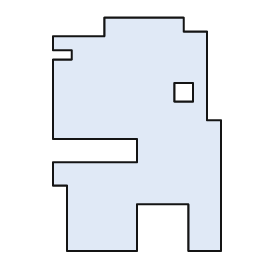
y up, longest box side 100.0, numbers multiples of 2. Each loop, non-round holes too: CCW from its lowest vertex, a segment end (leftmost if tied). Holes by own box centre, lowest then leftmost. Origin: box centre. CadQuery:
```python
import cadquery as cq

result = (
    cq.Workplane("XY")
    .moveTo(-30.0, -50.0)
    .lineTo(0.0, -50.0)
    .lineTo(0.0, -30.0)
    .lineTo(22.0, -30.0)
    .lineTo(22.0, -50.0)
    .lineTo(36.0, -50.0)
    .lineTo(36.0, 6.0)
    .lineTo(30.0, 6.0)
    .lineTo(30.0, 44.0)
    .lineTo(20.0, 44.0)
    .lineTo(20.0, 50.0)
    .lineTo(-14.0, 50.0)
    .lineTo(-14.0, 42.0)
    .lineTo(-36.0, 42.0)
    .lineTo(-36.0, 36.0)
    .lineTo(-28.0, 36.0)
    .lineTo(-28.0, 32.0)
    .lineTo(-36.0, 32.0)
    .lineTo(-36.0, -2.0)
    .lineTo(0.0, -2.0)
    .lineTo(0.0, -12.0)
    .lineTo(-36.0, -12.0)
    .lineTo(-36.0, -22.0)
    .lineTo(-30.0, -22.0)
    .close()
    .moveTo(16.0, 14.0)
    .lineTo(24.0, 14.0)
    .lineTo(24.0, 22.0)
    .lineTo(16.0, 22.0)
    .close()
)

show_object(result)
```